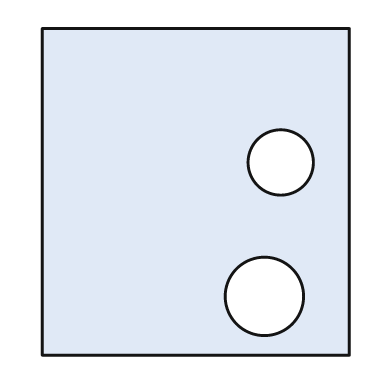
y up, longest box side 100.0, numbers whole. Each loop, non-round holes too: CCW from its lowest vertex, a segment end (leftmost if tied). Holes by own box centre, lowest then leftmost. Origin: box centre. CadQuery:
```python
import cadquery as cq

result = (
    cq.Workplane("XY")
    .moveTo(-47.0, -50.0)
    .lineTo(47.0, -50.0)
    .lineTo(47.0, 50.0)
    .lineTo(-47.0, 50.0)
    .close()
    .moveTo(21.0, -32.0)
    .circle(12.0)
    .moveTo(26.0, 9.0)
    .circle(10.0)
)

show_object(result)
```